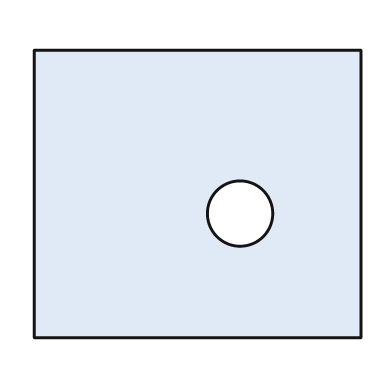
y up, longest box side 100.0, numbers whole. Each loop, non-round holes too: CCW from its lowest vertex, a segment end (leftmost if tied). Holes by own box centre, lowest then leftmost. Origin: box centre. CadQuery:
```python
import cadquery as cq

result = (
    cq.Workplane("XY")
    .moveTo(-50.0, -44.0)
    .lineTo(50.0, -44.0)
    .lineTo(50.0, 44.0)
    .lineTo(-50.0, 44.0)
    .close()
    .moveTo(13.0, -6.0)
    .circle(10.0)
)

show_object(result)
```